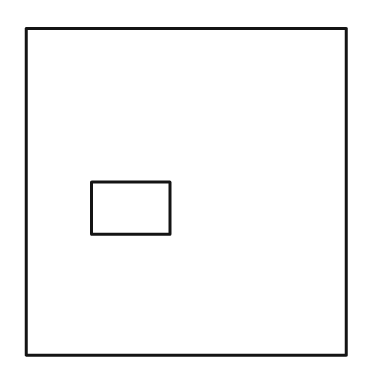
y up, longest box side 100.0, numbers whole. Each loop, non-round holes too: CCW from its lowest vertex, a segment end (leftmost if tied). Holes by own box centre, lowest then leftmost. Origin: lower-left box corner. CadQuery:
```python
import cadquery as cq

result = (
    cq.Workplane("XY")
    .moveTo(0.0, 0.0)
    .lineTo(98.0, 0.0)
    .lineTo(98.0, 100.0)
    .lineTo(0.0, 100.0)
    .close()
    .moveTo(20.0, 37.0)
    .lineTo(44.0, 37.0)
    .lineTo(44.0, 53.0)
    .lineTo(20.0, 53.0)
    .close()
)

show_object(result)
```